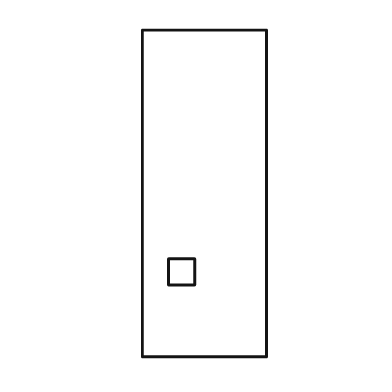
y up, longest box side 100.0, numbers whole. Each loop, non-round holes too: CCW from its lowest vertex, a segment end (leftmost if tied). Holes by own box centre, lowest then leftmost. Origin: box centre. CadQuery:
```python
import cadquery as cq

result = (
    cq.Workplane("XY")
    .moveTo(-19.0, -50.0)
    .lineTo(19.0, -50.0)
    .lineTo(19.0, 50.0)
    .lineTo(-19.0, 50.0)
    .close()
    .moveTo(-11.0, -28.0)
    .lineTo(-3.0, -28.0)
    .lineTo(-3.0, -20.0)
    .lineTo(-11.0, -20.0)
    .close()
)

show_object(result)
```